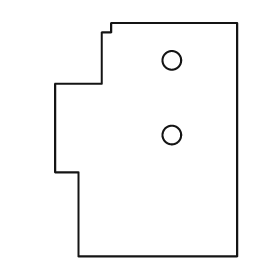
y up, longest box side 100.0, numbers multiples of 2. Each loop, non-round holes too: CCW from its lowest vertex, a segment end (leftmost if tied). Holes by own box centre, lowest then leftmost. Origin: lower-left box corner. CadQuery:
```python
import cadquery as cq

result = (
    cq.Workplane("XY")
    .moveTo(10.0, 0.0)
    .lineTo(78.0, 0.0)
    .lineTo(78.0, 100.0)
    .lineTo(24.0, 100.0)
    .lineTo(24.0, 96.0)
    .lineTo(20.0, 96.0)
    .lineTo(20.0, 74.0)
    .lineTo(0.0, 74.0)
    .lineTo(0.0, 36.0)
    .lineTo(10.0, 36.0)
    .close()
    .moveTo(50.0, 52.0)
    .circle(4.0)
    .moveTo(50.0, 84.0)
    .circle(4.0)
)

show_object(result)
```